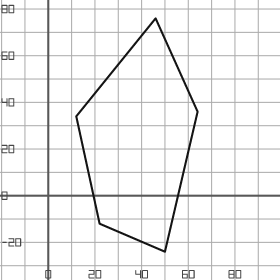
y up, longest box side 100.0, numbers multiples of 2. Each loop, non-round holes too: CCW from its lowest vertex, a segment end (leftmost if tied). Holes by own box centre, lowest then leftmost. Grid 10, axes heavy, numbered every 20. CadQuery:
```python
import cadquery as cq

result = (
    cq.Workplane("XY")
    .moveTo(50.0, -24.0)
    .lineTo(64.0, 36.0)
    .lineTo(46.0, 76.0)
    .lineTo(12.0, 34.0)
    .lineTo(22.0, -12.0)
    .close()
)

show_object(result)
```